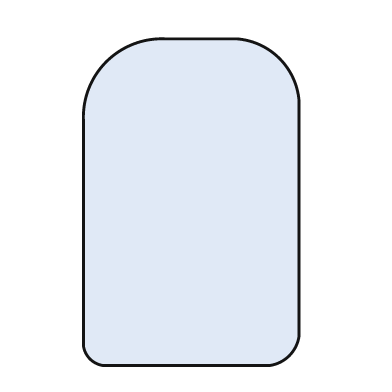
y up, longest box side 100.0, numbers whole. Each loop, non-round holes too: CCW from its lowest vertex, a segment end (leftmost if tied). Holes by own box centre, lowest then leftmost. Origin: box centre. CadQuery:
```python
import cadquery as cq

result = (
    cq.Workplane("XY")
    .moveTo(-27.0, -50.0)
    .lineTo(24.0, -50.0)
    .threePointArc((30.0, -47.0), (33.0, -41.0))
    .lineTo(33.0, 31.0)
    .threePointArc((27.0, 44.0), (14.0, 50.0))
    .lineTo(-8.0, 50.0)
    .threePointArc((-26.0, 43.0), (-33.0, 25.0))
    .lineTo(-33.0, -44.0)
    .threePointArc((-31.0, -48.0), (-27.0, -50.0))
    .close()
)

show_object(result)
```